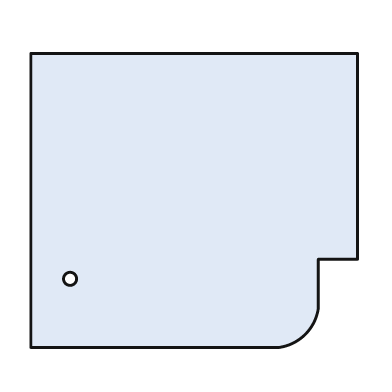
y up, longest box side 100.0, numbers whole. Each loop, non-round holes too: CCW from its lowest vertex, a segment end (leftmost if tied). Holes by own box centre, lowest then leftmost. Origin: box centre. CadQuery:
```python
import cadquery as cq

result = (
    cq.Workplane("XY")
    .moveTo(-50.0, -45.0)
    .lineTo(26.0, -45.0)
    .threePointArc((34.0, -41.0), (38.0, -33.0))
    .lineTo(38.0, -18.0)
    .lineTo(50.0, -18.0)
    .lineTo(50.0, 45.0)
    .lineTo(-50.0, 45.0)
    .close()
    .moveTo(-38.0, -24.0)
    .circle(2.0)
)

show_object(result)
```